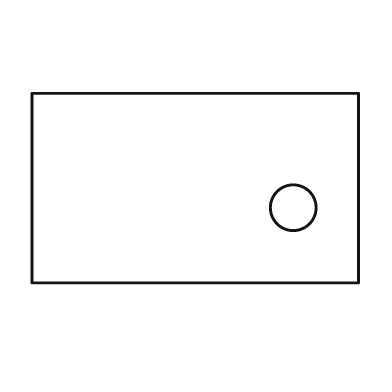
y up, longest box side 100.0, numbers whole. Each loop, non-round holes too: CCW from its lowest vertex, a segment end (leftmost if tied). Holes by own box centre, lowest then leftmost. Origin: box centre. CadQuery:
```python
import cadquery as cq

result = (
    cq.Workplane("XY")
    .moveTo(-50.0, -29.0)
    .lineTo(50.0, -29.0)
    .lineTo(50.0, 29.0)
    .lineTo(-50.0, 29.0)
    .close()
    .moveTo(30.0, -6.0)
    .circle(7.0)
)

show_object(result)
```